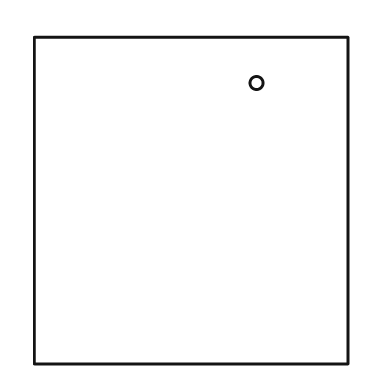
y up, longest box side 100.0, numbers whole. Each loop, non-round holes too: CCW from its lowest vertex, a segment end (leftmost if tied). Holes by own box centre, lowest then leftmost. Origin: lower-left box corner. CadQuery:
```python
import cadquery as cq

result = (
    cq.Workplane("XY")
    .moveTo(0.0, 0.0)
    .lineTo(96.0, 0.0)
    .lineTo(96.0, 100.0)
    .lineTo(0.0, 100.0)
    .close()
    .moveTo(68.0, 86.0)
    .circle(2.0)
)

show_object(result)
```